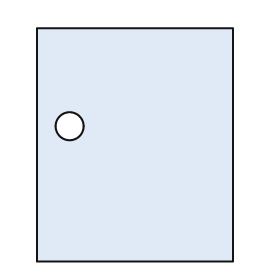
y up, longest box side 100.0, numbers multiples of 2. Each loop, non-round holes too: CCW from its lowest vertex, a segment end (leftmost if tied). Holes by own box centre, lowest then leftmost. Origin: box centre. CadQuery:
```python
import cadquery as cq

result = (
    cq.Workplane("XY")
    .moveTo(-42.0, -50.0)
    .lineTo(42.0, -50.0)
    .lineTo(42.0, 50.0)
    .lineTo(-42.0, 50.0)
    .close()
    .moveTo(-28.0, 8.0)
    .circle(6.0)
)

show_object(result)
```